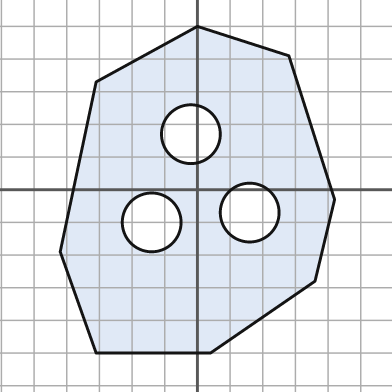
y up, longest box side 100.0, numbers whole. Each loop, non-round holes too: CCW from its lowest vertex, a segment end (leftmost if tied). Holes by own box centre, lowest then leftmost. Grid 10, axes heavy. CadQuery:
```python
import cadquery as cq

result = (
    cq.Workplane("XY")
    .moveTo(-31.0, -50.0)
    .lineTo(4.0, -50.0)
    .lineTo(36.0, -28.0)
    .lineTo(42.0, -3.0)
    .lineTo(28.0, 41.0)
    .lineTo(0.0, 50.0)
    .lineTo(-31.0, 33.0)
    .lineTo(-42.0, -19.0)
    .close()
    .moveTo(-14.0, -10.0)
    .circle(9.0)
    .moveTo(16.0, -7.0)
    .circle(9.0)
    .moveTo(-2.0, 17.0)
    .circle(9.0)
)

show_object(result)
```